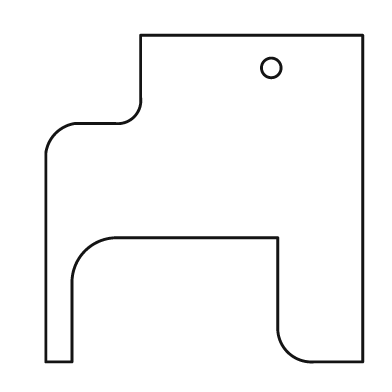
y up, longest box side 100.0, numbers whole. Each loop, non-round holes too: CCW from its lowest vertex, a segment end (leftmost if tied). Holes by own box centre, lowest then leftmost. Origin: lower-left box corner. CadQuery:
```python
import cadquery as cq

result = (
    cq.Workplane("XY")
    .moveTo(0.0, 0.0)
    .lineTo(8.0, 0.0)
    .lineTo(8.0, 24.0)
    .threePointArc((12.0, 34.0), (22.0, 38.0))
    .lineTo(71.0, 38.0)
    .lineTo(71.0, 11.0)
    .threePointArc((74.0, 3.0), (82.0, 0.0))
    .lineTo(97.0, 0.0)
    .lineTo(97.0, 100.0)
    .lineTo(29.0, 100.0)
    .lineTo(29.0, 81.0)
    .threePointArc((27.0, 75.0), (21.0, 73.0))
    .lineTo(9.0, 73.0)
    .threePointArc((3.0, 70.0), (0.0, 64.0))
    .close()
    .moveTo(69.0, 90.0)
    .circle(3.0)
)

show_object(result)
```